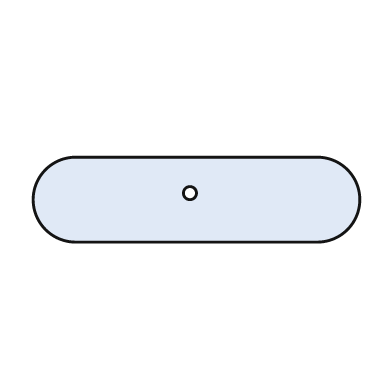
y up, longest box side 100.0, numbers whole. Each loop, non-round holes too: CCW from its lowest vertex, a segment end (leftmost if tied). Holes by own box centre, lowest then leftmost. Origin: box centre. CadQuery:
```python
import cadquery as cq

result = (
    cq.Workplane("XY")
    .moveTo(-37.0, -13.0)
    .lineTo(37.0, -13.0)
    .threePointArc((50.0, 0.0), (37.0, 13.0))
    .lineTo(-37.0, 13.0)
    .threePointArc((-50.0, 0.0), (-37.0, -13.0))
    .close()
    .moveTo(-2.0, 2.0)
    .circle(2.0)
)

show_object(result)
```